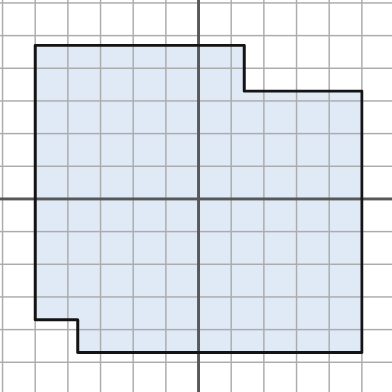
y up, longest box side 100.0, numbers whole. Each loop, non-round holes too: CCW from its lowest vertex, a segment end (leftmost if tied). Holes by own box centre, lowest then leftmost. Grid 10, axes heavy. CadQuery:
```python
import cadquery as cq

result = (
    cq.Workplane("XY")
    .moveTo(-37.0, -47.0)
    .lineTo(50.0, -47.0)
    .lineTo(50.0, 33.0)
    .lineTo(14.0, 33.0)
    .lineTo(14.0, 47.0)
    .lineTo(-50.0, 47.0)
    .lineTo(-50.0, -37.0)
    .lineTo(-37.0, -37.0)
    .close()
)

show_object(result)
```